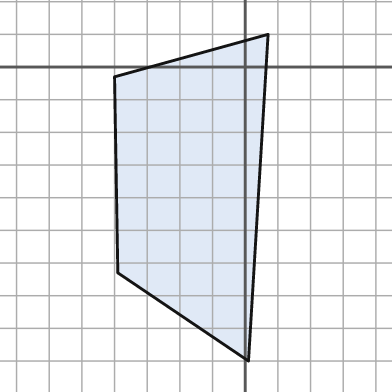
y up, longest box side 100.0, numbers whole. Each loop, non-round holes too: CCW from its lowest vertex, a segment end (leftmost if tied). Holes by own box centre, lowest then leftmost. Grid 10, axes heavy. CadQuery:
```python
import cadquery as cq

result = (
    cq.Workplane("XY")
    .moveTo(1.0, -90.0)
    .lineTo(7.0, 10.0)
    .lineTo(-40.0, -3.0)
    .lineTo(-39.0, -63.0)
    .close()
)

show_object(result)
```